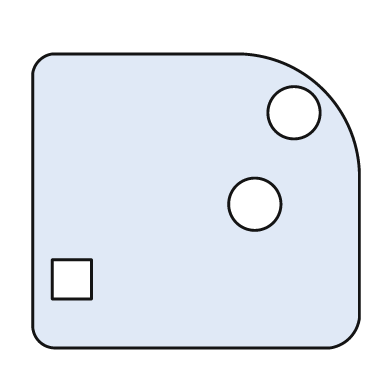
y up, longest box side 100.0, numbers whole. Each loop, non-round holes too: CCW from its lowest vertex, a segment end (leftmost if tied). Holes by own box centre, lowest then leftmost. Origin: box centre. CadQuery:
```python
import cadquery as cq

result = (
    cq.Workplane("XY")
    .moveTo(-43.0, -45.0)
    .lineTo(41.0, -45.0)
    .threePointArc((47.0, -42.0), (50.0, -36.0))
    .lineTo(50.0, 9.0)
    .threePointArc((39.0, 34.0), (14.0, 45.0))
    .lineTo(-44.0, 45.0)
    .threePointArc((-48.0, 43.0), (-50.0, 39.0))
    .lineTo(-50.0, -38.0)
    .threePointArc((-48.0, -43.0), (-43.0, -45.0))
    .close()
    .moveTo(-44.0, -30.0)
    .lineTo(-32.0, -30.0)
    .lineTo(-32.0, -18.0)
    .lineTo(-44.0, -18.0)
    .close()
    .moveTo(18.0, -1.0)
    .circle(8.0)
    .moveTo(30.0, 27.0)
    .circle(8.0)
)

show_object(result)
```